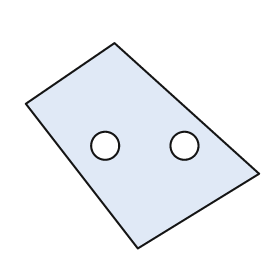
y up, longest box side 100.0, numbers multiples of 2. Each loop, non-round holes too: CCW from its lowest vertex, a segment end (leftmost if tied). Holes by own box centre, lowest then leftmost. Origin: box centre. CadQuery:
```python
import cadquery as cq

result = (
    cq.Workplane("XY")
    .moveTo(-2.0, -44.0)
    .lineTo(50.0, -12.0)
    .lineTo(-12.0, 44.0)
    .lineTo(-50.0, 18.0)
    .close()
    .moveTo(-16.0, 0.0)
    .circle(6.0)
    .moveTo(18.0, 0.0)
    .circle(6.0)
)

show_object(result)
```